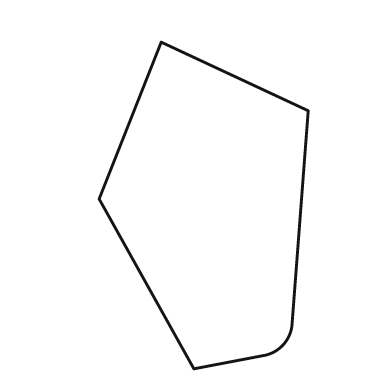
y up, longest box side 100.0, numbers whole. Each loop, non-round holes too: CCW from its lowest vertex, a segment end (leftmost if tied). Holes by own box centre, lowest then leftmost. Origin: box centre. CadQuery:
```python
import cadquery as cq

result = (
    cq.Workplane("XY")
    .moveTo(-3.0, -50.0)
    .lineTo(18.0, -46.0)
    .threePointArc((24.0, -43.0), (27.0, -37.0))
    .lineTo(32.0, 29.0)
    .lineTo(-13.0, 50.0)
    .lineTo(-32.0, 2.0)
    .close()
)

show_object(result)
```